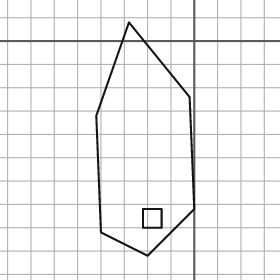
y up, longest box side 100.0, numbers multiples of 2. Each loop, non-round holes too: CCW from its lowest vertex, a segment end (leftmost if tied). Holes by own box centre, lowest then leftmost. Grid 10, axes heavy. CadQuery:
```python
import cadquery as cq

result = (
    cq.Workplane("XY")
    .moveTo(-20.0, -92.0)
    .lineTo(0.0, -72.0)
    .lineTo(-2.0, -24.0)
    .lineTo(-28.0, 8.0)
    .lineTo(-42.0, -32.0)
    .lineTo(-40.0, -82.0)
    .close()
    .moveTo(-22.0, -80.0)
    .lineTo(-14.0, -80.0)
    .lineTo(-14.0, -72.0)
    .lineTo(-22.0, -72.0)
    .close()
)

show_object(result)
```